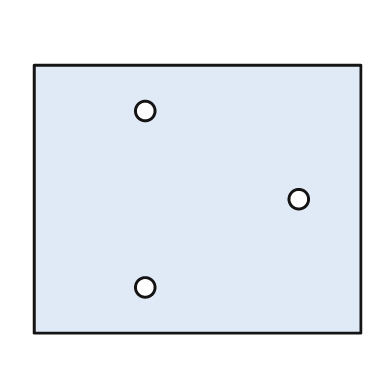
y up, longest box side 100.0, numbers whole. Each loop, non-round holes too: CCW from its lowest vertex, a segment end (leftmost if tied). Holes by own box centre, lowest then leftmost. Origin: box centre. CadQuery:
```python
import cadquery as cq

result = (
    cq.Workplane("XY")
    .moveTo(-50.0, -41.0)
    .lineTo(50.0, -41.0)
    .lineTo(50.0, 41.0)
    .lineTo(-50.0, 41.0)
    .close()
    .moveTo(-16.0, -27.0)
    .circle(3.0)
    .moveTo(31.0, 0.0)
    .circle(3.0)
    .moveTo(-16.0, 27.0)
    .circle(3.0)
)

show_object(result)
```